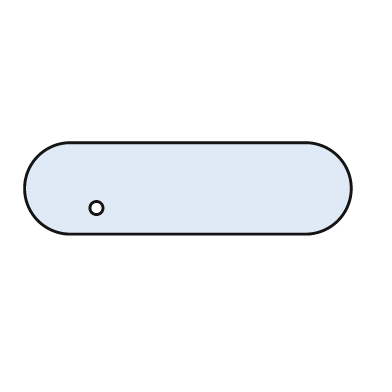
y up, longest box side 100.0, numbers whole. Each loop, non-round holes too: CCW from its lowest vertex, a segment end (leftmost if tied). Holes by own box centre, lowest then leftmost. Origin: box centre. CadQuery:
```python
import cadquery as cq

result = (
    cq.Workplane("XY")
    .moveTo(-36.0, -14.0)
    .lineTo(36.0, -14.0)
    .threePointArc((50.0, 0.0), (36.0, 14.0))
    .lineTo(-36.0, 14.0)
    .threePointArc((-50.0, 0.0), (-36.0, -14.0))
    .close()
    .moveTo(-28.0, -6.0)
    .circle(2.0)
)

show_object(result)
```